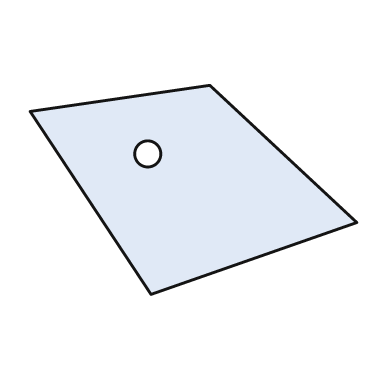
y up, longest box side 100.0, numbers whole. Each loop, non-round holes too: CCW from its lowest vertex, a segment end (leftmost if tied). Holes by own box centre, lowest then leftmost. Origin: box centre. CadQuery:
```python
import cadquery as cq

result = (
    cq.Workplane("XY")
    .moveTo(-13.0, -32.0)
    .lineTo(50.0, -10.0)
    .lineTo(5.0, 32.0)
    .lineTo(-50.0, 24.0)
    .close()
    .moveTo(-14.0, 11.0)
    .circle(4.0)
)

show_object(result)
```